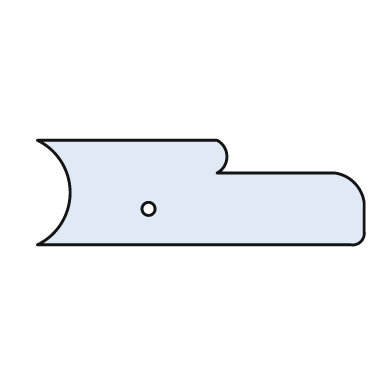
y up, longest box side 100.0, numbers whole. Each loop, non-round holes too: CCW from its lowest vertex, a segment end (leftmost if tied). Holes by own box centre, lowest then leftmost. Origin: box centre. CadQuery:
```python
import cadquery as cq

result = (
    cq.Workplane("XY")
    .moveTo(-50.0, -16.0)
    .lineTo(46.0, -16.0)
    .threePointArc((49.0, -15.0), (50.0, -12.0))
    .lineTo(50.0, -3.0)
    .threePointArc((47.0, 3.0), (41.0, 6.0))
    .lineTo(5.0, 6.0)
    .threePointArc((8.0, 11.0), (5.0, 16.0))
    .lineTo(-50.0, 16.0)
    .threePointArc((-40.0, 0.0), (-50.0, -16.0))
    .close()
    .moveTo(-16.0, -5.0)
    .circle(2.0)
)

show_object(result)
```